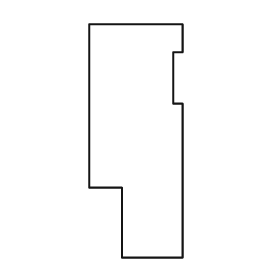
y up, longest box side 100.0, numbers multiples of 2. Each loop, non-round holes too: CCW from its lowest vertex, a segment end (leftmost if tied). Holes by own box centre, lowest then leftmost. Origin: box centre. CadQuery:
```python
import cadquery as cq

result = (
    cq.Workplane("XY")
    .moveTo(-6.0, -50.0)
    .lineTo(20.0, -50.0)
    .lineTo(20.0, 16.0)
    .lineTo(16.0, 16.0)
    .lineTo(16.0, 38.0)
    .lineTo(20.0, 38.0)
    .lineTo(20.0, 50.0)
    .lineTo(-20.0, 50.0)
    .lineTo(-20.0, -20.0)
    .lineTo(-6.0, -20.0)
    .close()
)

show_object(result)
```